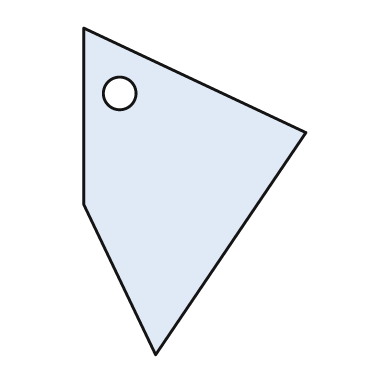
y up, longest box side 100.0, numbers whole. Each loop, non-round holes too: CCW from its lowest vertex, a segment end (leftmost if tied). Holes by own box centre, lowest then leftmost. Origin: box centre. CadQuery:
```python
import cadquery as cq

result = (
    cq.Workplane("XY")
    .moveTo(-12.0, -50.0)
    .lineTo(34.0, 18.0)
    .lineTo(-34.0, 50.0)
    .lineTo(-34.0, -4.0)
    .close()
    .moveTo(-23.0, 30.0)
    .circle(5.0)
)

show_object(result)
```